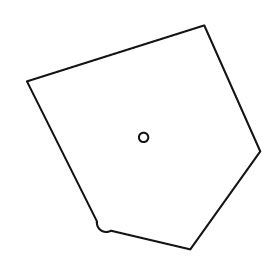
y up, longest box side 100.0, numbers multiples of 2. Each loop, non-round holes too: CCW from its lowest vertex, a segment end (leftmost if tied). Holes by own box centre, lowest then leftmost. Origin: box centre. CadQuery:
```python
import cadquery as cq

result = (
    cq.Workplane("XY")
    .moveTo(20.0, -48.0)
    .lineTo(50.0, -6.0)
    .lineTo(26.0, 48.0)
    .lineTo(-50.0, 24.0)
    .lineTo(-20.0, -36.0)
    .threePointArc((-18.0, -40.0), (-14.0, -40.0))
    .close()
    .moveTo(0.0, 0.0)
    .circle(2.0)
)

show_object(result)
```